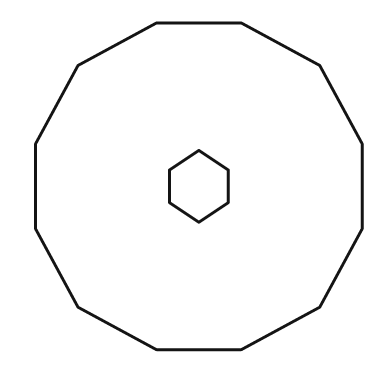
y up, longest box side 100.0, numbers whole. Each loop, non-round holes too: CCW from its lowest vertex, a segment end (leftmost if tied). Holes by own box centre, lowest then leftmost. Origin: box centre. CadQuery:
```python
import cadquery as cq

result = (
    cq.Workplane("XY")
    .moveTo(-13.0, -50.0)
    .lineTo(13.0, -50.0)
    .lineTo(37.0, -37.0)
    .lineTo(50.0, -13.0)
    .lineTo(50.0, 13.0)
    .lineTo(37.0, 37.0)
    .lineTo(13.0, 50.0)
    .lineTo(-13.0, 50.0)
    .lineTo(-37.0, 37.0)
    .lineTo(-50.0, 13.0)
    .lineTo(-50.0, -13.0)
    .lineTo(-37.0, -37.0)
    .close()
    .moveTo(0.0, -11.0)
    .lineTo(9.0, -5.0)
    .lineTo(9.0, 5.0)
    .lineTo(0.0, 11.0)
    .lineTo(-9.0, 5.0)
    .lineTo(-9.0, -5.0)
    .close()
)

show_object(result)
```